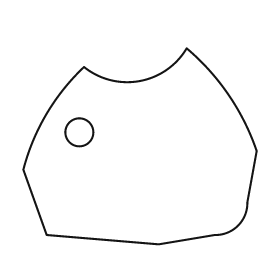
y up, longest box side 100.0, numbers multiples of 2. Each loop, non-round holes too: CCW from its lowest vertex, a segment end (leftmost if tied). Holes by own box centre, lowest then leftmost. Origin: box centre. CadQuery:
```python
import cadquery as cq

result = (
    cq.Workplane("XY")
    .moveTo(8.0, -42.0)
    .lineTo(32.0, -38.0)
    .threePointArc((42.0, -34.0), (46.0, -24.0))
    .lineTo(50.0, -2.0)
    .threePointArc((38.0, 22.0), (20.0, 42.0))
    .threePointArc((0.0, 28.0), (-24.0, 34.0))
    .threePointArc((-40.0, 14.0), (-50.0, -10.0))
    .lineTo(-40.0, -38.0)
    .close()
    .moveTo(-26.0, 6.0)
    .circle(6.0)
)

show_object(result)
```